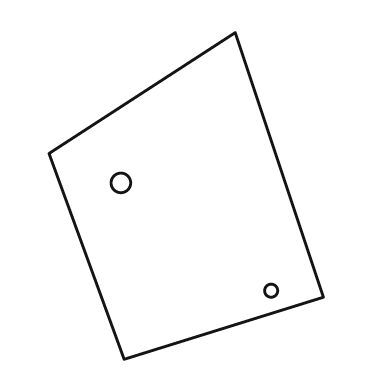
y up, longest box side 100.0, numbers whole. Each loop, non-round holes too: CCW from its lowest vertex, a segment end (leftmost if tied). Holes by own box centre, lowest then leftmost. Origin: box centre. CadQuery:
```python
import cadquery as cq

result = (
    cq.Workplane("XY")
    .moveTo(-19.0, -50.0)
    .lineTo(42.0, -31.0)
    .lineTo(15.0, 50.0)
    .lineTo(-42.0, 13.0)
    .close()
    .moveTo(26.0, -29.0)
    .circle(2.0)
    .moveTo(-20.0, 4.0)
    .circle(3.0)
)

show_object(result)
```